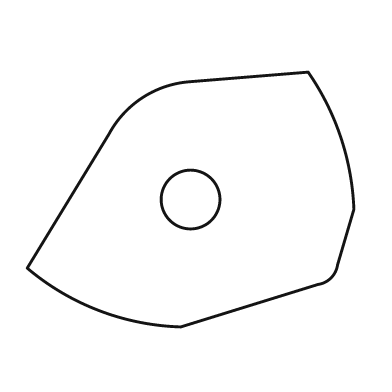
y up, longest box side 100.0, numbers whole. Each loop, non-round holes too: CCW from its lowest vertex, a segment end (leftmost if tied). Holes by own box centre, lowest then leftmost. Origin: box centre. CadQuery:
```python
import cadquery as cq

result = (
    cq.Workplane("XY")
    .moveTo(-3.0, -39.0)
    .lineTo(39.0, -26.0)
    .threePointArc((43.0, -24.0), (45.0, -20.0))
    .lineTo(50.0, -3.0)
    .threePointArc((46.0, 19.0), (36.0, 39.0))
    .lineTo(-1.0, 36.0)
    .threePointArc((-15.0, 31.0), (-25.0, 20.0))
    .lineTo(-50.0, -21.0)
    .threePointArc((-28.0, -34.0), (-3.0, -39.0))
    .close()
    .moveTo(0.0, 0.0)
    .circle(9.0)
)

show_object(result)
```